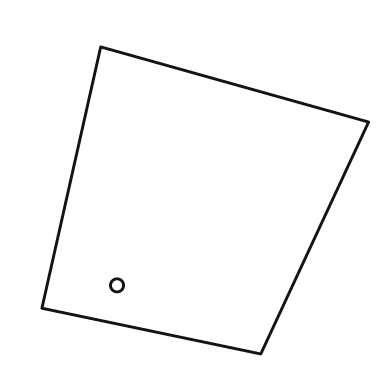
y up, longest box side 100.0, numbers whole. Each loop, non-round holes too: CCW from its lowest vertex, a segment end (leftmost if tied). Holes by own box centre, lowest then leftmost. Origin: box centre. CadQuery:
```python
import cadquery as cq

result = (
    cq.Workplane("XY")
    .moveTo(17.0, -47.0)
    .lineTo(50.0, 24.0)
    .lineTo(-32.0, 47.0)
    .lineTo(-50.0, -33.0)
    .close()
    .moveTo(-27.0, -26.0)
    .circle(2.0)
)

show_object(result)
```